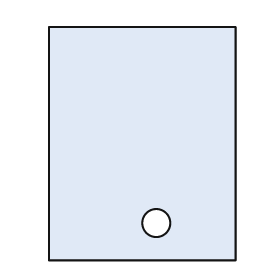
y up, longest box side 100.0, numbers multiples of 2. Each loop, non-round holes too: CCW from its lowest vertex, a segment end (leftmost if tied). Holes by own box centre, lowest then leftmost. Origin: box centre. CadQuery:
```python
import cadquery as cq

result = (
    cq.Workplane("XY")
    .moveTo(-40.0, -50.0)
    .lineTo(40.0, -50.0)
    .lineTo(40.0, 50.0)
    .lineTo(-40.0, 50.0)
    .close()
    .moveTo(6.0, -34.0)
    .circle(6.0)
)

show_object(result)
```